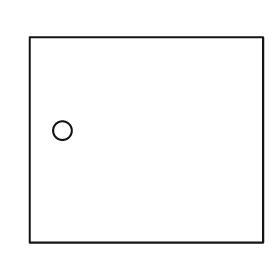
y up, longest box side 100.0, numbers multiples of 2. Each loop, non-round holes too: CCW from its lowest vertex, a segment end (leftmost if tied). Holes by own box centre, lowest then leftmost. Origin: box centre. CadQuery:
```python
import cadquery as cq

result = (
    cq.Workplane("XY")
    .moveTo(-50.0, -44.0)
    .lineTo(50.0, -44.0)
    .lineTo(50.0, 44.0)
    .lineTo(-50.0, 44.0)
    .close()
    .moveTo(-36.0, 4.0)
    .circle(4.0)
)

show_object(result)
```